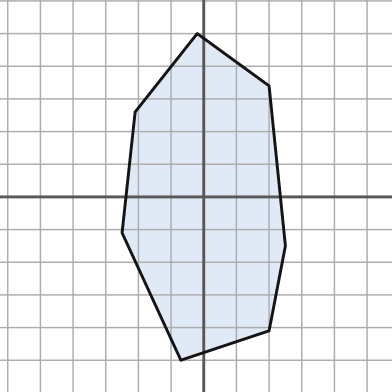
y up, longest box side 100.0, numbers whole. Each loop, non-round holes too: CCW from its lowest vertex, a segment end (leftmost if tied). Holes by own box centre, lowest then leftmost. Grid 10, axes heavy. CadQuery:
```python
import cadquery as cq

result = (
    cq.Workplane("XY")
    .moveTo(-7.0, -50.0)
    .lineTo(20.0, -41.0)
    .lineTo(25.0, -15.0)
    .lineTo(20.0, 34.0)
    .lineTo(-2.0, 50.0)
    .lineTo(-21.0, 26.0)
    .lineTo(-25.0, -11.0)
    .close()
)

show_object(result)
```